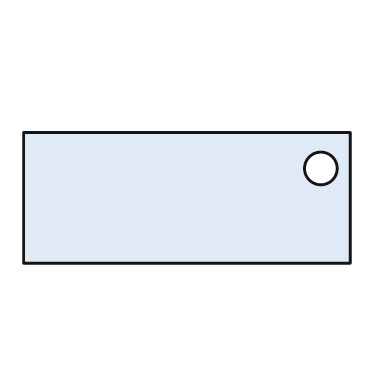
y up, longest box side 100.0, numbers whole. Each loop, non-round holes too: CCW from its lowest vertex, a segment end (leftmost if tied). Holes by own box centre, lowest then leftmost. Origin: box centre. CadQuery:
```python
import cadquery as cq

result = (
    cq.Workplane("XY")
    .moveTo(-50.0, -20.0)
    .lineTo(50.0, -20.0)
    .lineTo(50.0, 20.0)
    .lineTo(-50.0, 20.0)
    .close()
    .moveTo(41.0, 9.0)
    .circle(5.0)
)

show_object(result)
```